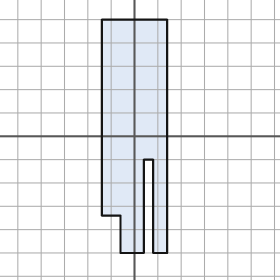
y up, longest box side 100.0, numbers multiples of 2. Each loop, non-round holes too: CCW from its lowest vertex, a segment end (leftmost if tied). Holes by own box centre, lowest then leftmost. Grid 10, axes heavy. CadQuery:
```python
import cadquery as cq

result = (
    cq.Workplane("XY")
    .moveTo(-6.0, -50.0)
    .lineTo(4.0, -50.0)
    .lineTo(4.0, -10.0)
    .lineTo(8.0, -10.0)
    .lineTo(8.0, -50.0)
    .lineTo(14.0, -50.0)
    .lineTo(14.0, 50.0)
    .lineTo(-14.0, 50.0)
    .lineTo(-14.0, -34.0)
    .lineTo(-6.0, -34.0)
    .close()
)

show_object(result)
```